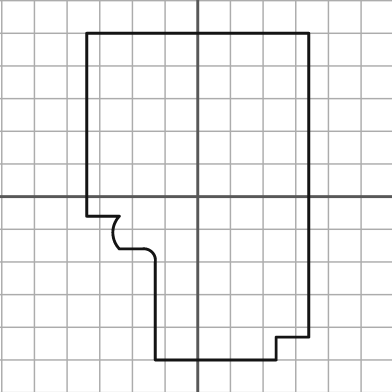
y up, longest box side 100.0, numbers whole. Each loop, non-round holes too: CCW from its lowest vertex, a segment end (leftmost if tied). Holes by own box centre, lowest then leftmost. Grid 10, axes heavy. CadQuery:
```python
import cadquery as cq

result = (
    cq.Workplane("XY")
    .moveTo(-13.0, -50.0)
    .lineTo(24.0, -50.0)
    .lineTo(24.0, -43.0)
    .lineTo(34.0, -43.0)
    .lineTo(34.0, 50.0)
    .lineTo(-34.0, 50.0)
    .lineTo(-34.0, -6.0)
    .lineTo(-24.0, -6.0)
    .threePointArc((-26.0, -11.0), (-24.0, -16.0))
    .lineTo(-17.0, -16.0)
    .threePointArc((-14.0, -17.0), (-13.0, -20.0))
    .close()
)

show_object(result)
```